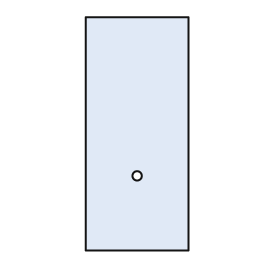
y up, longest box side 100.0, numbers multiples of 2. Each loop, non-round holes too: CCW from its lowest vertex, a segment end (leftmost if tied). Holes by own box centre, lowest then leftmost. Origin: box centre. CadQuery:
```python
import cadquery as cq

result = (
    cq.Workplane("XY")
    .moveTo(-22.0, -50.0)
    .lineTo(22.0, -50.0)
    .lineTo(22.0, 50.0)
    .lineTo(-22.0, 50.0)
    .close()
    .moveTo(0.0, -18.0)
    .circle(2.0)
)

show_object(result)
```